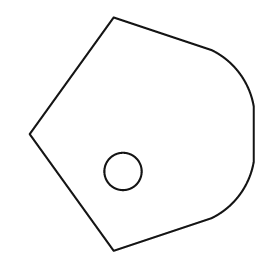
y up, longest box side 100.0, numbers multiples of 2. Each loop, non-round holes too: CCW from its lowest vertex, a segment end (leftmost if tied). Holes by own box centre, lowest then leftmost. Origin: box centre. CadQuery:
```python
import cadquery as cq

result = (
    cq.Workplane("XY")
    .moveTo(-12.0, -50.0)
    .lineTo(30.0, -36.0)
    .threePointArc((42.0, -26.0), (48.0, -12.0))
    .lineTo(48.0, 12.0)
    .threePointArc((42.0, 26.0), (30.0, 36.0))
    .lineTo(-12.0, 50.0)
    .lineTo(-48.0, 0.0)
    .close()
    .moveTo(-8.0, -16.0)
    .circle(8.0)
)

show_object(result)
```